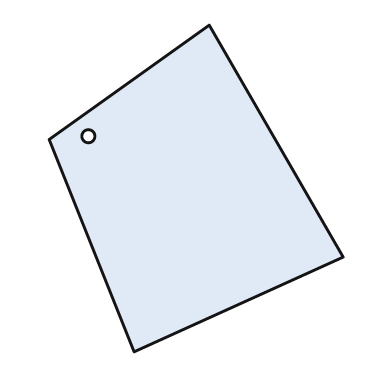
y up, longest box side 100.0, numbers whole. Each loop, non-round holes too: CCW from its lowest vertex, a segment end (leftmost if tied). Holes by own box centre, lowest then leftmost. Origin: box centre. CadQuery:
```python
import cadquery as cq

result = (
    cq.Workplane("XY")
    .moveTo(-19.0, -50.0)
    .lineTo(45.0, -21.0)
    .lineTo(4.0, 50.0)
    .lineTo(-45.0, 15.0)
    .close()
    .moveTo(-33.0, 16.0)
    .circle(2.0)
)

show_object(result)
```